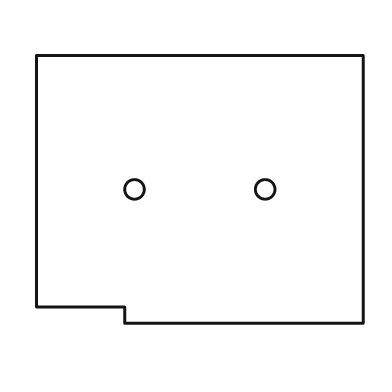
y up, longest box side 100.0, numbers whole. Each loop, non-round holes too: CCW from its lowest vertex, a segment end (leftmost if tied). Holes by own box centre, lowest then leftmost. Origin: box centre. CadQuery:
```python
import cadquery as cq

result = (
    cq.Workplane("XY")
    .moveTo(-23.0, -41.0)
    .lineTo(50.0, -41.0)
    .lineTo(50.0, 41.0)
    .lineTo(-50.0, 41.0)
    .lineTo(-50.0, -36.0)
    .lineTo(-23.0, -36.0)
    .close()
    .moveTo(-20.0, 0.0)
    .circle(3.0)
    .moveTo(20.0, 0.0)
    .circle(3.0)
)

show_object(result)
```